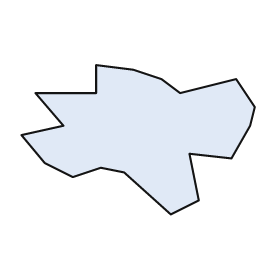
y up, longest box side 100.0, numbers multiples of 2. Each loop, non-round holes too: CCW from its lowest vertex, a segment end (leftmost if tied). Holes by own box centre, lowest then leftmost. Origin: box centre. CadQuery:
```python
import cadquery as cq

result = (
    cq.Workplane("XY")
    .moveTo(14.0, -32.0)
    .lineTo(26.0, -26.0)
    .lineTo(22.0, -6.0)
    .lineTo(40.0, -8.0)
    .lineTo(48.0, 6.0)
    .lineTo(50.0, 14.0)
    .lineTo(42.0, 26.0)
    .lineTo(18.0, 20.0)
    .lineTo(10.0, 26.0)
    .lineTo(-2.0, 30.0)
    .lineTo(-18.0, 32.0)
    .lineTo(-18.0, 20.0)
    .lineTo(-44.0, 20.0)
    .lineTo(-32.0, 6.0)
    .lineTo(-50.0, 2.0)
    .lineTo(-40.0, -10.0)
    .lineTo(-28.0, -16.0)
    .lineTo(-16.0, -12.0)
    .lineTo(-6.0, -14.0)
    .close()
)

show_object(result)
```